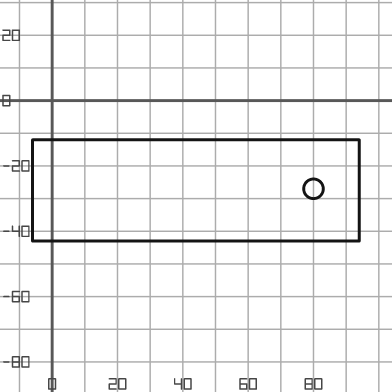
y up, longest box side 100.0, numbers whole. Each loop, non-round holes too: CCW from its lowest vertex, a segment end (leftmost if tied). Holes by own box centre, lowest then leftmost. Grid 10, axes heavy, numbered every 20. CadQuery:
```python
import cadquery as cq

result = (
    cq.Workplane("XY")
    .moveTo(-6.0, -43.0)
    .lineTo(94.0, -43.0)
    .lineTo(94.0, -12.0)
    .lineTo(-6.0, -12.0)
    .close()
    .moveTo(80.0, -27.0)
    .circle(3.0)
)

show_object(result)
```